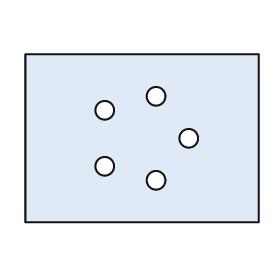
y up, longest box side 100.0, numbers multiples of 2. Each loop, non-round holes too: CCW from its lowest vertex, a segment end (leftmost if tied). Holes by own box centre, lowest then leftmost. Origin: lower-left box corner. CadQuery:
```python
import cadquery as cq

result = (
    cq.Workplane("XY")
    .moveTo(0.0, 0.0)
    .lineTo(100.0, 0.0)
    .lineTo(100.0, 72.0)
    .lineTo(0.0, 72.0)
    .close()
    .moveTo(56.0, 18.0)
    .circle(4.0)
    .moveTo(34.0, 24.0)
    .circle(4.0)
    .moveTo(70.0, 36.0)
    .circle(4.0)
    .moveTo(34.0, 48.0)
    .circle(4.0)
    .moveTo(56.0, 54.0)
    .circle(4.0)
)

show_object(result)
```